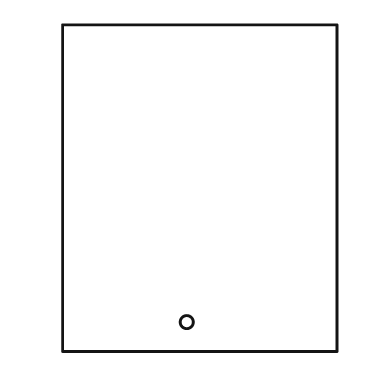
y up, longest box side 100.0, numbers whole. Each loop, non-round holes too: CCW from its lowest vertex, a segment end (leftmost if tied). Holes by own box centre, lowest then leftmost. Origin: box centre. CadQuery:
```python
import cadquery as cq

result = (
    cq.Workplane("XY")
    .moveTo(-42.0, -50.0)
    .lineTo(42.0, -50.0)
    .lineTo(42.0, 50.0)
    .lineTo(-42.0, 50.0)
    .close()
    .moveTo(-4.0, -41.0)
    .circle(2.0)
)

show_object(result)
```